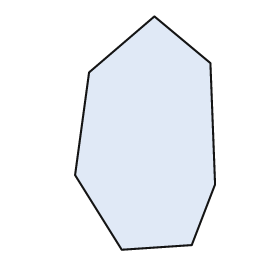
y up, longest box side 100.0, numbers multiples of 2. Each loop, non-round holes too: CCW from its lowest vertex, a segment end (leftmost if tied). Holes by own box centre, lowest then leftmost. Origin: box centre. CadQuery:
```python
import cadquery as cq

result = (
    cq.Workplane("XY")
    .moveTo(-10.0, -50.0)
    .lineTo(20.0, -48.0)
    .lineTo(30.0, -22.0)
    .lineTo(28.0, 30.0)
    .lineTo(4.0, 50.0)
    .lineTo(-24.0, 26.0)
    .lineTo(-30.0, -18.0)
    .close()
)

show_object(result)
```